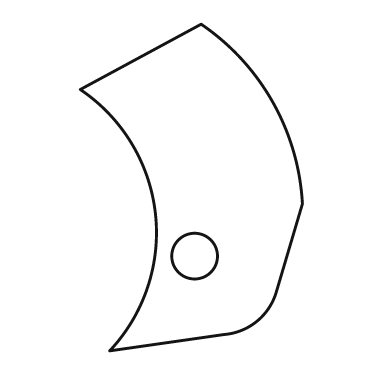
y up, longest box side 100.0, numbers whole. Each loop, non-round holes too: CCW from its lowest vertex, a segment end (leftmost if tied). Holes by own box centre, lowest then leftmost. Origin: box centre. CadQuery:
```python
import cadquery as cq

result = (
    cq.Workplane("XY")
    .moveTo(-25.0, -50.0)
    .lineTo(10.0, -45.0)
    .threePointArc((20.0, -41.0), (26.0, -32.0))
    .lineTo(34.0, -5.0)
    .threePointArc((25.0, 26.0), (3.0, 50.0))
    .lineTo(-34.0, 30.0)
    .threePointArc((-11.0, -8.0), (-25.0, -50.0))
    .close()
    .moveTo(1.0, -21.0)
    .circle(7.0)
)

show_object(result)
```